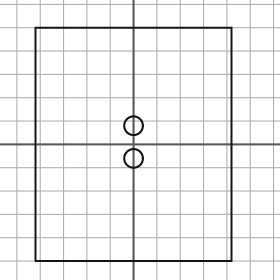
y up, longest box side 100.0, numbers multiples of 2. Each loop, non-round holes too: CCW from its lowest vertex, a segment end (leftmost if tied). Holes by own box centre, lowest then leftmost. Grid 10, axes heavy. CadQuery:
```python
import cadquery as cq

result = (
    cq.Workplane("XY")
    .moveTo(-42.0, -50.0)
    .lineTo(42.0, -50.0)
    .lineTo(42.0, 50.0)
    .lineTo(-42.0, 50.0)
    .close()
    .moveTo(0.0, -6.0)
    .circle(4.0)
    .moveTo(0.0, 8.0)
    .circle(4.0)
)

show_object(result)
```